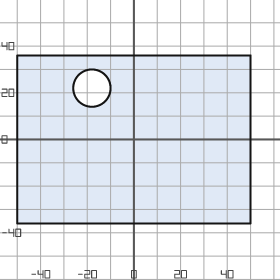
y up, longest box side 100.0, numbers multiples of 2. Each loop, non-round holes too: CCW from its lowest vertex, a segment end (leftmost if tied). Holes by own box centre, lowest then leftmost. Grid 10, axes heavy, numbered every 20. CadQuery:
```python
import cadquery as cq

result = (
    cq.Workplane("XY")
    .moveTo(-50.0, -36.0)
    .lineTo(50.0, -36.0)
    .lineTo(50.0, 36.0)
    .lineTo(-50.0, 36.0)
    .close()
    .moveTo(-18.0, 22.0)
    .circle(8.0)
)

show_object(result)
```